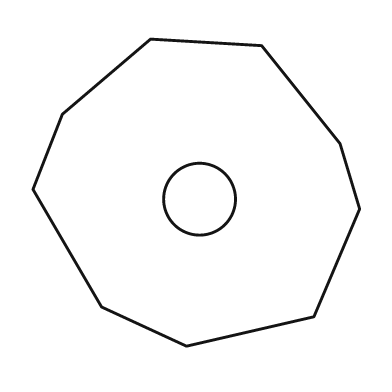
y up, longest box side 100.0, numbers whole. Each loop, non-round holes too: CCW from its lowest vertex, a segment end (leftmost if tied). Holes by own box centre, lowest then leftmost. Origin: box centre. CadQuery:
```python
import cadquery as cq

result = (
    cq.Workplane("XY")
    .moveTo(-3.0, -47.0)
    .lineTo(36.0, -38.0)
    .lineTo(50.0, -5.0)
    .lineTo(44.0, 15.0)
    .lineTo(20.0, 45.0)
    .lineTo(-14.0, 47.0)
    .lineTo(-41.0, 24.0)
    .lineTo(-50.0, 1.0)
    .lineTo(-29.0, -35.0)
    .close()
    .moveTo(1.0, -2.0)
    .circle(11.0)
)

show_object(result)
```